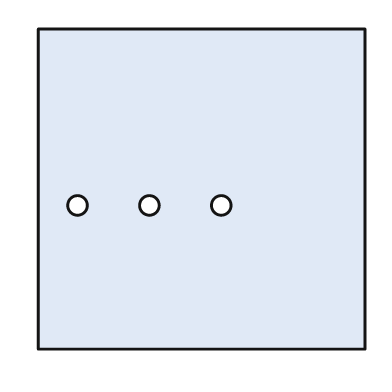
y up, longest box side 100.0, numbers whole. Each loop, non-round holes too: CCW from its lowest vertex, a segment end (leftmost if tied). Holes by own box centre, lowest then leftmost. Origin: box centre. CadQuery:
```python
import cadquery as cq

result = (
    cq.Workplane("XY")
    .moveTo(-50.0, -49.0)
    .lineTo(50.0, -49.0)
    .lineTo(50.0, 49.0)
    .lineTo(-50.0, 49.0)
    .close()
    .moveTo(-38.0, -5.0)
    .circle(3.0)
    .moveTo(-16.0, -5.0)
    .circle(3.0)
    .moveTo(6.0, -5.0)
    .circle(3.0)
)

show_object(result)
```